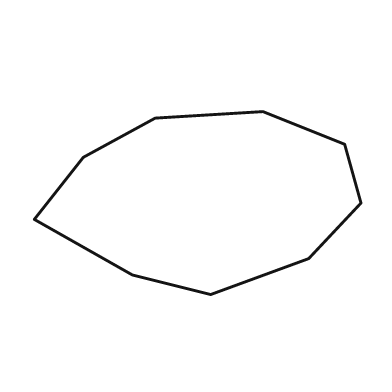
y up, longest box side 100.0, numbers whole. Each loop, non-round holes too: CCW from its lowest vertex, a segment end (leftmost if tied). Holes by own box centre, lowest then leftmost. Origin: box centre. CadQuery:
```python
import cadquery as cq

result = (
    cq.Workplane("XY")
    .moveTo(4.0, -28.0)
    .lineTo(34.0, -17.0)
    .lineTo(50.0, 0.0)
    .lineTo(45.0, 18.0)
    .lineTo(20.0, 28.0)
    .lineTo(-13.0, 26.0)
    .lineTo(-35.0, 14.0)
    .lineTo(-50.0, -5.0)
    .lineTo(-20.0, -22.0)
    .close()
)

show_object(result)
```